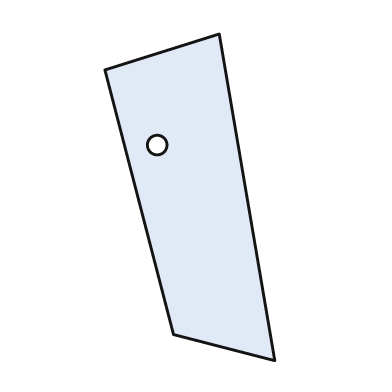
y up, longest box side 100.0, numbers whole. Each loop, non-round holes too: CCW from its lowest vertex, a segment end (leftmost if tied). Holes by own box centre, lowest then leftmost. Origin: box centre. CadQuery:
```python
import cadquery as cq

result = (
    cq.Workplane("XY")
    .moveTo(26.0, -50.0)
    .lineTo(9.0, 50.0)
    .lineTo(-26.0, 39.0)
    .lineTo(-5.0, -42.0)
    .close()
    .moveTo(-10.0, 16.0)
    .circle(3.0)
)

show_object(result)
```